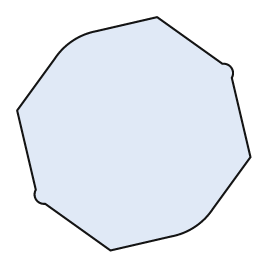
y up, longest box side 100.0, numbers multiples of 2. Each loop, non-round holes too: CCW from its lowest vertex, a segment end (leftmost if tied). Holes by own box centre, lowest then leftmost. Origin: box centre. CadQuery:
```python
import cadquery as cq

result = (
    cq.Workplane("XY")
    .moveTo(-10.0, -50.0)
    .lineTo(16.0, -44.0)
    .threePointArc((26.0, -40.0), (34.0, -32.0))
    .lineTo(50.0, -10.0)
    .lineTo(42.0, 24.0)
    .threePointArc((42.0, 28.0), (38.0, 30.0))
    .lineTo(10.0, 50.0)
    .lineTo(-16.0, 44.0)
    .threePointArc((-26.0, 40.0), (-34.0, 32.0))
    .lineTo(-50.0, 10.0)
    .lineTo(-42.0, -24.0)
    .threePointArc((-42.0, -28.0), (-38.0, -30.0))
    .close()
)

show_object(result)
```